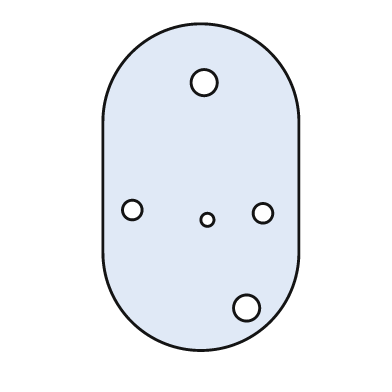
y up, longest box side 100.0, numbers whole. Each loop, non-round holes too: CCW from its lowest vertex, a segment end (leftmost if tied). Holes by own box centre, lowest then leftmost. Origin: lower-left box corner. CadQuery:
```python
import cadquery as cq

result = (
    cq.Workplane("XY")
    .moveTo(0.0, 30.0)
    .threePointArc((30.0, 0.0), (60.0, 30.0))
    .lineTo(60.0, 70.0)
    .threePointArc((30.0, 100.0), (0.0, 70.0))
    .close()
    .moveTo(44.0, 13.0)
    .circle(4.0)
    .moveTo(32.0, 40.0)
    .circle(2.0)
    .moveTo(49.0, 42.0)
    .circle(3.0)
    .moveTo(9.0, 43.0)
    .circle(3.0)
    .moveTo(31.0, 82.0)
    .circle(4.0)
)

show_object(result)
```